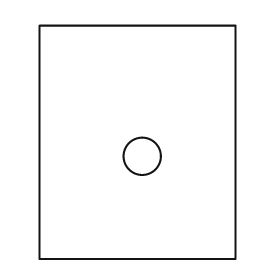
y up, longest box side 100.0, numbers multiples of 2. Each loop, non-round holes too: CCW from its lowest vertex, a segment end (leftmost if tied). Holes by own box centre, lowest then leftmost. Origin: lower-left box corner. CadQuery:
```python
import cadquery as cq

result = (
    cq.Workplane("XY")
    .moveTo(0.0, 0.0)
    .lineTo(84.0, 0.0)
    .lineTo(84.0, 100.0)
    .lineTo(0.0, 100.0)
    .close()
    .moveTo(44.0, 44.0)
    .circle(8.0)
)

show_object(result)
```